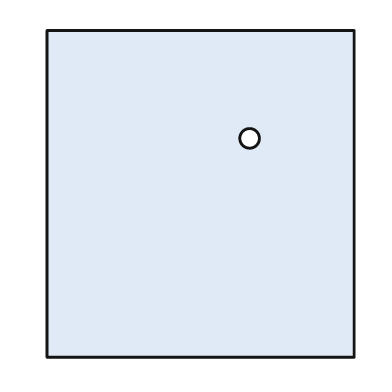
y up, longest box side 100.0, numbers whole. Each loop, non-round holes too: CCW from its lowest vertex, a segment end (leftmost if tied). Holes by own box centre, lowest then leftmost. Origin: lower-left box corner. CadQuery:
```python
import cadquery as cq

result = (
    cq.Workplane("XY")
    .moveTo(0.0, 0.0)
    .lineTo(94.0, 0.0)
    .lineTo(94.0, 100.0)
    .lineTo(0.0, 100.0)
    .close()
    .moveTo(62.0, 67.0)
    .circle(3.0)
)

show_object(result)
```